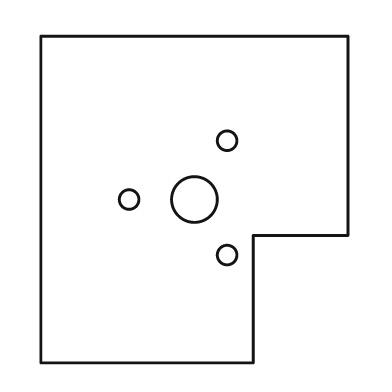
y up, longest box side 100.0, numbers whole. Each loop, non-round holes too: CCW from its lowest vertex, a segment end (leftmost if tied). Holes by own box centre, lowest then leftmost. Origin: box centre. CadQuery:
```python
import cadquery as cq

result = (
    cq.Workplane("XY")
    .moveTo(-47.0, -50.0)
    .lineTo(18.0, -50.0)
    .lineTo(18.0, -11.0)
    .lineTo(47.0, -11.0)
    .lineTo(47.0, 50.0)
    .lineTo(-47.0, 50.0)
    .close()
    .moveTo(10.0, -17.0)
    .circle(3.0)
    .moveTo(-20.0, 0.0)
    .circle(3.0)
    .moveTo(0.0, 0.0)
    .circle(7.0)
    .moveTo(10.0, 18.0)
    .circle(3.0)
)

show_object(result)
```